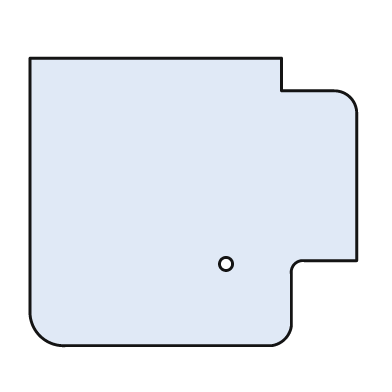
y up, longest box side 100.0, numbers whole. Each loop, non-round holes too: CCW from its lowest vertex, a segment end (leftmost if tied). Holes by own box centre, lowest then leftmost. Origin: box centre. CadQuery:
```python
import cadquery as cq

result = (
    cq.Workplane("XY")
    .moveTo(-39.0, -44.0)
    .lineTo(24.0, -44.0)
    .threePointArc((28.0, -42.0), (30.0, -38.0))
    .lineTo(30.0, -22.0)
    .threePointArc((31.0, -19.0), (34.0, -18.0))
    .lineTo(50.0, -18.0)
    .lineTo(50.0, 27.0)
    .threePointArc((48.0, 32.0), (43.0, 34.0))
    .lineTo(27.0, 34.0)
    .lineTo(27.0, 44.0)
    .lineTo(-50.0, 44.0)
    .lineTo(-50.0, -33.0)
    .threePointArc((-47.0, -41.0), (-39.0, -44.0))
    .close()
    .moveTo(10.0, -19.0)
    .circle(2.0)
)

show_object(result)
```